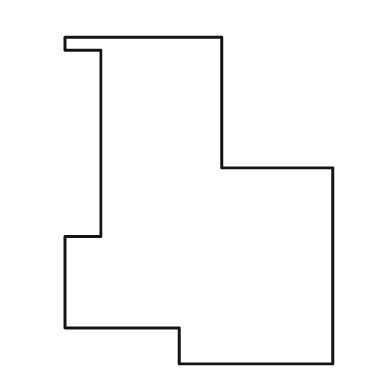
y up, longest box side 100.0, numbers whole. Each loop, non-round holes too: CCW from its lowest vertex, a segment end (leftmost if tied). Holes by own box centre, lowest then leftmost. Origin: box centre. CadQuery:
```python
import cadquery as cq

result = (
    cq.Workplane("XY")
    .moveTo(-6.0, -50.0)
    .lineTo(41.0, -50.0)
    .lineTo(41.0, 10.0)
    .lineTo(7.0, 10.0)
    .lineTo(7.0, 50.0)
    .lineTo(-41.0, 50.0)
    .lineTo(-41.0, 46.0)
    .lineTo(-30.0, 46.0)
    .lineTo(-30.0, -11.0)
    .lineTo(-41.0, -11.0)
    .lineTo(-41.0, -39.0)
    .lineTo(-6.0, -39.0)
    .close()
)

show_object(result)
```